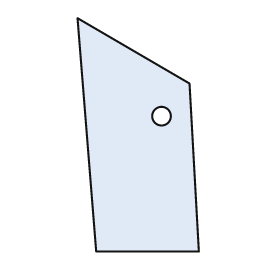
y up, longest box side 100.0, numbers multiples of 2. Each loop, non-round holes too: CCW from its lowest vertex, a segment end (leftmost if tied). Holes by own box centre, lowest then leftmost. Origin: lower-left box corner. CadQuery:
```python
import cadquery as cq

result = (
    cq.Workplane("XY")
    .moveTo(8.0, 0.0)
    .lineTo(52.0, 0.0)
    .lineTo(48.0, 72.0)
    .lineTo(0.0, 100.0)
    .close()
    .moveTo(36.0, 58.0)
    .circle(4.0)
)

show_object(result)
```